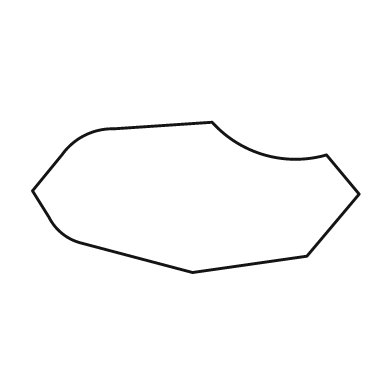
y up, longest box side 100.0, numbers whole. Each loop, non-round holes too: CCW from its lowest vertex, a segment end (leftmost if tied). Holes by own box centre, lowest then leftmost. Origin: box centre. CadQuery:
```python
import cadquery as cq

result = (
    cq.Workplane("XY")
    .moveTo(-1.0, -23.0)
    .lineTo(34.0, -18.0)
    .lineTo(50.0, 1.0)
    .lineTo(40.0, 13.0)
    .threePointArc((21.0, 13.0), (5.0, 23.0))
    .lineTo(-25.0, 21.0)
    .threePointArc((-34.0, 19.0), (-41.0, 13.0))
    .lineTo(-50.0, 2.0)
    .lineTo(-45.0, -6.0)
    .threePointArc((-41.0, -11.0), (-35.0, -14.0))
    .close()
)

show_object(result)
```